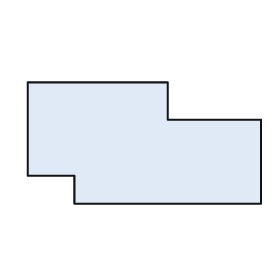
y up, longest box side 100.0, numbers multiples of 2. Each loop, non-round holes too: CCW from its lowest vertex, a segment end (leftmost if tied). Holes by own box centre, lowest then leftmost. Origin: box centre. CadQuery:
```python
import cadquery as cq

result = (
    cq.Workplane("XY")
    .moveTo(-30.0, -26.0)
    .lineTo(50.0, -26.0)
    .lineTo(50.0, 10.0)
    .lineTo(10.0, 10.0)
    .lineTo(10.0, 26.0)
    .lineTo(-50.0, 26.0)
    .lineTo(-50.0, -14.0)
    .lineTo(-30.0, -14.0)
    .close()
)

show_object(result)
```